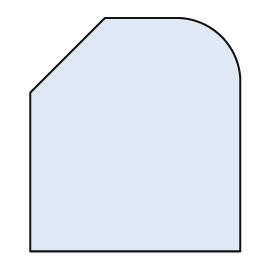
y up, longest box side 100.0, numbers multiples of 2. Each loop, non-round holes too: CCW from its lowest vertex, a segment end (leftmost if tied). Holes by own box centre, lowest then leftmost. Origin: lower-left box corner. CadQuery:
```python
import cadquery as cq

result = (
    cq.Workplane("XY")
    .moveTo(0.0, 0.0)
    .lineTo(90.0, 0.0)
    .lineTo(90.0, 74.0)
    .threePointArc((82.0, 92.0), (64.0, 100.0))
    .lineTo(32.0, 100.0)
    .lineTo(0.0, 68.0)
    .close()
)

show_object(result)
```